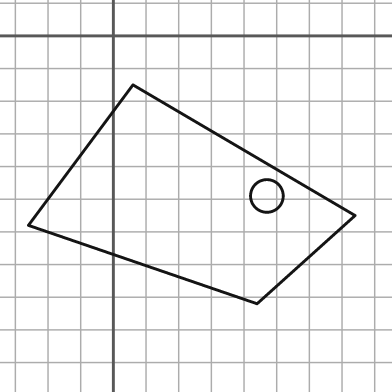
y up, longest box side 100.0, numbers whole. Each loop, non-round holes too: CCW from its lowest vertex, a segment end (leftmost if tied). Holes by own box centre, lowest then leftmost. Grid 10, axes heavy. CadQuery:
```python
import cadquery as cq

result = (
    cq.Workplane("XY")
    .moveTo(44.0, -82.0)
    .lineTo(74.0, -55.0)
    .lineTo(6.0, -15.0)
    .lineTo(-26.0, -58.0)
    .close()
    .moveTo(47.0, -49.0)
    .circle(5.0)
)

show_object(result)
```